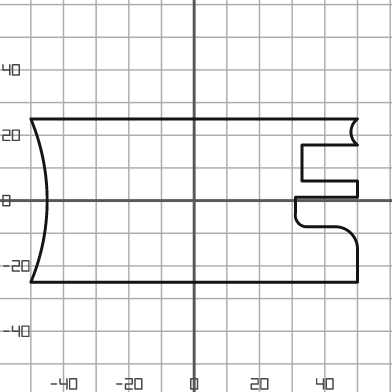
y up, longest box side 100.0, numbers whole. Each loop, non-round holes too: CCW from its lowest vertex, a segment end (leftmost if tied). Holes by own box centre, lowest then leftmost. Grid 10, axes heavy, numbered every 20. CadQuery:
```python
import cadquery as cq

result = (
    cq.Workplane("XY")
    .moveTo(-50.0, -25.0)
    .lineTo(50.0, -25.0)
    .lineTo(50.0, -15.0)
    .threePointArc((48.0, -10.0), (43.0, -8.0))
    .lineTo(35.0, -8.0)
    .threePointArc((32.0, -7.0), (31.0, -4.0))
    .lineTo(31.0, 1.0)
    .lineTo(50.0, 1.0)
    .lineTo(50.0, 6.0)
    .lineTo(33.0, 6.0)
    .lineTo(33.0, 17.0)
    .lineTo(50.0, 17.0)
    .threePointArc((48.0, 21.0), (50.0, 25.0))
    .lineTo(-50.0, 25.0)
    .threePointArc((-45.0, 0.0), (-50.0, -25.0))
    .close()
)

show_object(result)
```